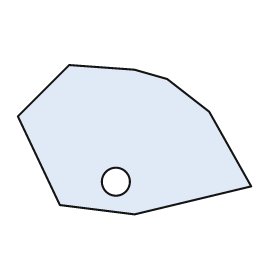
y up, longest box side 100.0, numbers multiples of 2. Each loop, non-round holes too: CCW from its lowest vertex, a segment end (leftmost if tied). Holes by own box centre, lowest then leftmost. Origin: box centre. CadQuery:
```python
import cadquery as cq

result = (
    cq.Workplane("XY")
    .moveTo(0.0, -32.0)
    .lineTo(50.0, -20.0)
    .lineTo(32.0, 12.0)
    .lineTo(14.0, 26.0)
    .lineTo(0.0, 30.0)
    .lineTo(-28.0, 32.0)
    .lineTo(-50.0, 10.0)
    .lineTo(-32.0, -28.0)
    .close()
    .moveTo(-8.0, -18.0)
    .circle(6.0)
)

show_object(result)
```